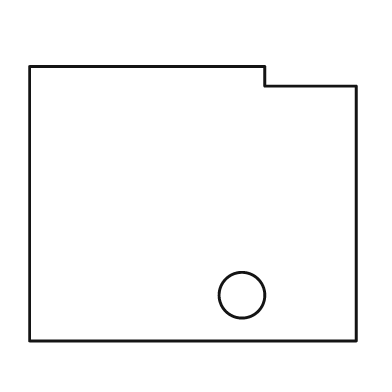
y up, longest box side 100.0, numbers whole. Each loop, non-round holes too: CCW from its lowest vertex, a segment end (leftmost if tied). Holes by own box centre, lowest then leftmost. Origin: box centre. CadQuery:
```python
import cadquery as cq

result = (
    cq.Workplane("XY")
    .moveTo(-50.0, -42.0)
    .lineTo(50.0, -42.0)
    .lineTo(50.0, 36.0)
    .lineTo(22.0, 36.0)
    .lineTo(22.0, 42.0)
    .lineTo(-50.0, 42.0)
    .close()
    .moveTo(15.0, -28.0)
    .circle(7.0)
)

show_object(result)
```